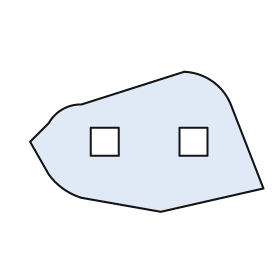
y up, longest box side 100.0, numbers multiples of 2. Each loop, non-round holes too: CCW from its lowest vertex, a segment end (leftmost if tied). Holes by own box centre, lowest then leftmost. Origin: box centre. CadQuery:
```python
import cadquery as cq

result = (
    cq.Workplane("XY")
    .moveTo(6.0, -30.0)
    .lineTo(50.0, -20.0)
    .lineTo(36.0, 16.0)
    .threePointArc((28.0, 26.0), (16.0, 30.0))
    .lineTo(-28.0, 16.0)
    .threePointArc((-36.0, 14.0), (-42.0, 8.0))
    .lineTo(-50.0, 0.0)
    .lineTo(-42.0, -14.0)
    .threePointArc((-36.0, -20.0), (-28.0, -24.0))
    .close()
    .moveTo(-24.0, -6.0)
    .lineTo(-12.0, -6.0)
    .lineTo(-12.0, 6.0)
    .lineTo(-24.0, 6.0)
    .close()
    .moveTo(14.0, -6.0)
    .lineTo(26.0, -6.0)
    .lineTo(26.0, 6.0)
    .lineTo(14.0, 6.0)
    .close()
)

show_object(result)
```